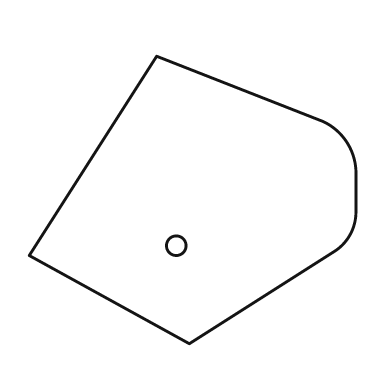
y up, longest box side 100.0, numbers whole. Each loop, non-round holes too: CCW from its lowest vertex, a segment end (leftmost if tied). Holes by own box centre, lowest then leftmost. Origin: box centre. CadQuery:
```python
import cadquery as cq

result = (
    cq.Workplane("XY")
    .moveTo(-1.0, -44.0)
    .lineTo(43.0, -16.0)
    .threePointArc((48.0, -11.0), (50.0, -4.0))
    .lineTo(50.0, 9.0)
    .threePointArc((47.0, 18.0), (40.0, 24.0))
    .lineTo(-11.0, 44.0)
    .lineTo(-50.0, -17.0)
    .close()
    .moveTo(-5.0, -14.0)
    .circle(3.0)
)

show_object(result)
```